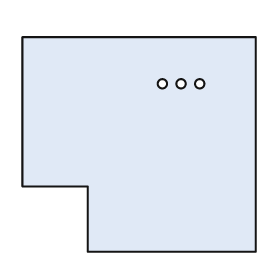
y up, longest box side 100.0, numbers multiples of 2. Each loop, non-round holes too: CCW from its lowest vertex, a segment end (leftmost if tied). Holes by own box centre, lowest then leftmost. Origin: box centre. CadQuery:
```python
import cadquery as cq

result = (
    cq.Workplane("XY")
    .moveTo(-22.0, -46.0)
    .lineTo(50.0, -46.0)
    .lineTo(50.0, 46.0)
    .lineTo(-50.0, 46.0)
    .lineTo(-50.0, -18.0)
    .lineTo(-22.0, -18.0)
    .close()
    .moveTo(10.0, 26.0)
    .circle(2.0)
    .moveTo(18.0, 26.0)
    .circle(2.0)
    .moveTo(26.0, 26.0)
    .circle(2.0)
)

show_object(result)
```